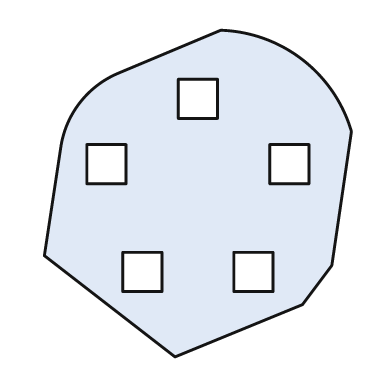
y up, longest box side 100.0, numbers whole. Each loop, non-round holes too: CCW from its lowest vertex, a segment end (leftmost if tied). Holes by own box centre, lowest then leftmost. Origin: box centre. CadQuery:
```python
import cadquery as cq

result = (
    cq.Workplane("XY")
    .moveTo(-7.0, -50.0)
    .lineTo(32.0, -34.0)
    .lineTo(41.0, -22.0)
    .lineTo(47.0, 19.0)
    .threePointArc((32.0, 41.0), (7.0, 50.0))
    .lineTo(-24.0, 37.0)
    .threePointArc((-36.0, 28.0), (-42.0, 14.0))
    .lineTo(-47.0, -19.0)
    .close()
    .moveTo(-23.0, -30.0)
    .lineTo(-11.0, -30.0)
    .lineTo(-11.0, -18.0)
    .lineTo(-23.0, -18.0)
    .close()
    .moveTo(11.0, -30.0)
    .lineTo(23.0, -30.0)
    .lineTo(23.0, -18.0)
    .lineTo(11.0, -18.0)
    .close()
    .moveTo(-34.0, 3.0)
    .lineTo(-22.0, 3.0)
    .lineTo(-22.0, 15.0)
    .lineTo(-34.0, 15.0)
    .close()
    .moveTo(22.0, 3.0)
    .lineTo(34.0, 3.0)
    .lineTo(34.0, 15.0)
    .lineTo(22.0, 15.0)
    .close()
    .moveTo(-6.0, 23.0)
    .lineTo(6.0, 23.0)
    .lineTo(6.0, 35.0)
    .lineTo(-6.0, 35.0)
    .close()
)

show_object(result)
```